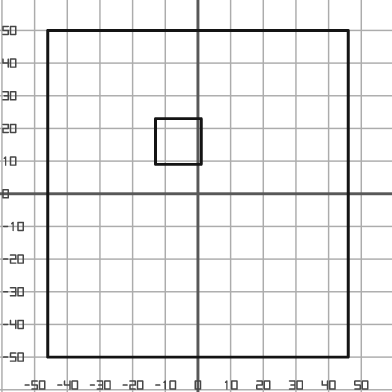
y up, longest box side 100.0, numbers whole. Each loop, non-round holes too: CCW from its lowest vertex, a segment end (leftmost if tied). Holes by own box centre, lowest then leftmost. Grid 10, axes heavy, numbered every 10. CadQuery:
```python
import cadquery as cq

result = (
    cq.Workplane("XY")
    .moveTo(-46.0, -50.0)
    .lineTo(46.0, -50.0)
    .lineTo(46.0, 50.0)
    .lineTo(-46.0, 50.0)
    .close()
    .moveTo(-13.0, 9.0)
    .lineTo(1.0, 9.0)
    .lineTo(1.0, 23.0)
    .lineTo(-13.0, 23.0)
    .close()
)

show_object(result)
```